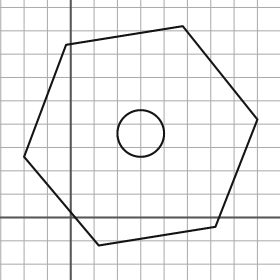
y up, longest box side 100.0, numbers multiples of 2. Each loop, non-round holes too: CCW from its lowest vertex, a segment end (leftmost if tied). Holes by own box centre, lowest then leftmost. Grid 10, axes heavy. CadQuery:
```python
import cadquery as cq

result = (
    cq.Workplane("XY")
    .moveTo(12.0, -12.0)
    .lineTo(62.0, -4.0)
    .lineTo(80.0, 42.0)
    .lineTo(48.0, 82.0)
    .lineTo(-2.0, 74.0)
    .lineTo(-20.0, 26.0)
    .close()
    .moveTo(30.0, 36.0)
    .circle(10.0)
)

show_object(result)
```